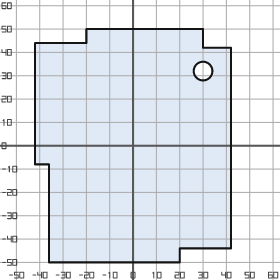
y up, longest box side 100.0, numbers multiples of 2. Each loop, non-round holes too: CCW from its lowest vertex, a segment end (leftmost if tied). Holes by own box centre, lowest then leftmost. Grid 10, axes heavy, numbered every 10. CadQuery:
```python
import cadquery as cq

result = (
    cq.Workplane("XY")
    .moveTo(-36.0, -50.0)
    .lineTo(20.0, -50.0)
    .lineTo(20.0, -44.0)
    .lineTo(42.0, -44.0)
    .lineTo(42.0, 42.0)
    .lineTo(30.0, 42.0)
    .lineTo(30.0, 50.0)
    .lineTo(-20.0, 50.0)
    .lineTo(-20.0, 44.0)
    .lineTo(-42.0, 44.0)
    .lineTo(-42.0, -8.0)
    .lineTo(-36.0, -8.0)
    .close()
    .moveTo(30.0, 32.0)
    .circle(4.0)
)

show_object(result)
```